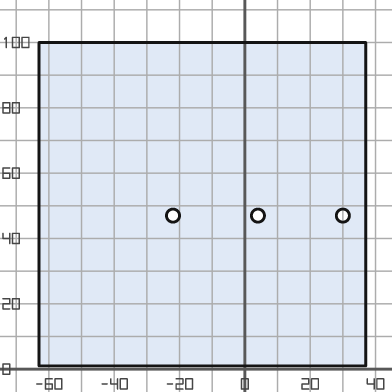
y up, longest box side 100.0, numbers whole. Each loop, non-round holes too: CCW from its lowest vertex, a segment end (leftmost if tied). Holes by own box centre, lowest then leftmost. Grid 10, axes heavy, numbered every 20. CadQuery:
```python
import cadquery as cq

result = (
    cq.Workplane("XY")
    .moveTo(-63.0, 1.0)
    .lineTo(37.0, 1.0)
    .lineTo(37.0, 100.0)
    .lineTo(-63.0, 100.0)
    .close()
    .moveTo(-22.0, 47.0)
    .circle(2.0)
    .moveTo(4.0, 47.0)
    .circle(2.0)
    .moveTo(30.0, 47.0)
    .circle(2.0)
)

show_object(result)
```